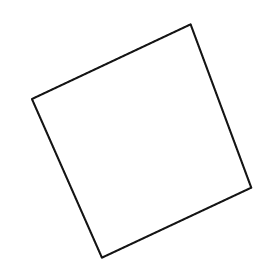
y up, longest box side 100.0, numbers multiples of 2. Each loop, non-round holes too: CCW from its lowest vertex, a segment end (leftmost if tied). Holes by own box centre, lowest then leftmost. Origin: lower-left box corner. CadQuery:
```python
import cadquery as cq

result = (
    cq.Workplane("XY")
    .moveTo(30.0, 0.0)
    .lineTo(94.0, 30.0)
    .lineTo(68.0, 100.0)
    .lineTo(0.0, 68.0)
    .close()
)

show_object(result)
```